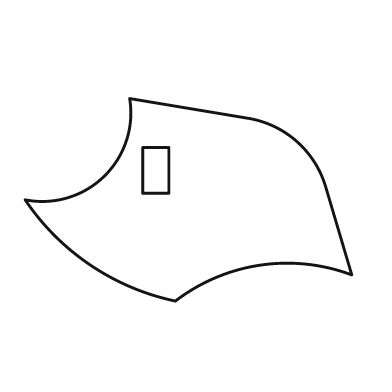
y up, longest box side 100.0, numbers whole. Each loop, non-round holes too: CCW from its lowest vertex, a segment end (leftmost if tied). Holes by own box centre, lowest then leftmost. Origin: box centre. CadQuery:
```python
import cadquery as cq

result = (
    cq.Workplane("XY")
    .moveTo(-4.0, -31.0)
    .threePointArc((22.0, -20.0), (50.0, -23.0))
    .lineTo(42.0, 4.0)
    .threePointArc((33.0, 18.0), (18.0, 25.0))
    .lineTo(-18.0, 31.0)
    .threePointArc((-26.0, 7.0), (-50.0, 0.0))
    .threePointArc((-30.0, -20.0), (-4.0, -31.0))
    .close()
    .moveTo(-14.0, 2.0)
    .lineTo(-6.0, 2.0)
    .lineTo(-6.0, 16.0)
    .lineTo(-14.0, 16.0)
    .close()
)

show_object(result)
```